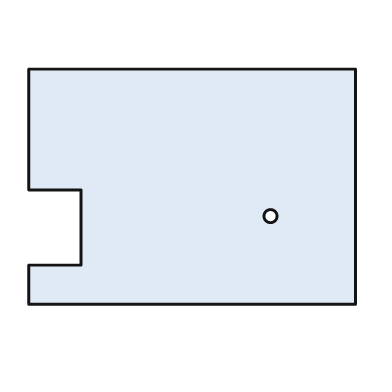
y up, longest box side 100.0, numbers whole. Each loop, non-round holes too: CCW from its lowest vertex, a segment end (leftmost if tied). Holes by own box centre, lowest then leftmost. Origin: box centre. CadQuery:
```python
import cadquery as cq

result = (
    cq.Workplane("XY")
    .moveTo(-50.0, -36.0)
    .lineTo(50.0, -36.0)
    .lineTo(50.0, 36.0)
    .lineTo(-50.0, 36.0)
    .lineTo(-50.0, -1.0)
    .lineTo(-34.0, -1.0)
    .lineTo(-34.0, -24.0)
    .lineTo(-50.0, -24.0)
    .close()
    .moveTo(24.0, -9.0)
    .circle(2.0)
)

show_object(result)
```